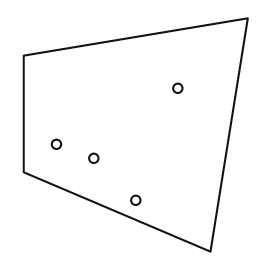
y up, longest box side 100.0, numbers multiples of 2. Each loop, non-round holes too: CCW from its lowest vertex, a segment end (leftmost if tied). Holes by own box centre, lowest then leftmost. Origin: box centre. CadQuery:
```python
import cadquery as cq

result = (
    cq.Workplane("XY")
    .moveTo(32.0, -50.0)
    .lineTo(48.0, 50.0)
    .lineTo(-48.0, 34.0)
    .lineTo(-48.0, -16.0)
    .close()
    .moveTo(0.0, -28.0)
    .circle(2.0)
    .moveTo(-18.0, -10.0)
    .circle(2.0)
    .moveTo(-34.0, -4.0)
    .circle(2.0)
    .moveTo(18.0, 20.0)
    .circle(2.0)
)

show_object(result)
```